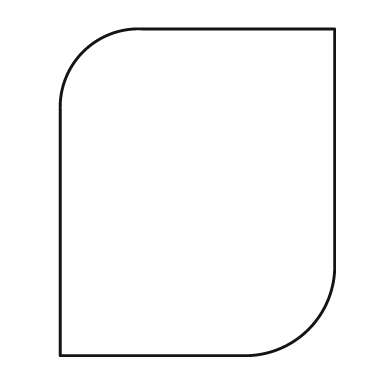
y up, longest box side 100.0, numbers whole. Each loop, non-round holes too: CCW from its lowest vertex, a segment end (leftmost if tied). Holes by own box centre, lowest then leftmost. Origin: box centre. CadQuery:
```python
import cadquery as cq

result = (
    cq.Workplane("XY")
    .moveTo(-42.0, -50.0)
    .lineTo(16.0, -50.0)
    .threePointArc((34.0, -42.0), (42.0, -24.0))
    .lineTo(42.0, 50.0)
    .lineTo(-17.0, 50.0)
    .threePointArc((-35.0, 43.0), (-42.0, 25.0))
    .close()
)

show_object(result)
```